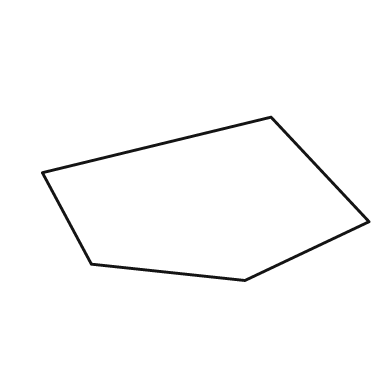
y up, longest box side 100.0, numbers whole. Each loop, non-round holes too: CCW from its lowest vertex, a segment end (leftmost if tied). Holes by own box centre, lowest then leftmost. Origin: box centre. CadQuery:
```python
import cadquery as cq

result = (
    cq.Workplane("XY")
    .moveTo(12.0, -25.0)
    .lineTo(50.0, -7.0)
    .lineTo(20.0, 25.0)
    .lineTo(-50.0, 8.0)
    .lineTo(-35.0, -20.0)
    .close()
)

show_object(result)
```